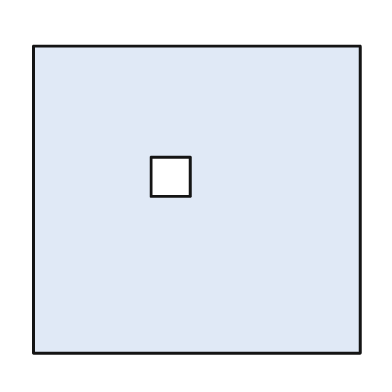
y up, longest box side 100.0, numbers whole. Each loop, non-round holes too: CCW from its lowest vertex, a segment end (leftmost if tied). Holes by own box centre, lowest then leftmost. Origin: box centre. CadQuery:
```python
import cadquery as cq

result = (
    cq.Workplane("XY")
    .moveTo(-50.0, -47.0)
    .lineTo(50.0, -47.0)
    .lineTo(50.0, 47.0)
    .lineTo(-50.0, 47.0)
    .close()
    .moveTo(-14.0, 1.0)
    .lineTo(-2.0, 1.0)
    .lineTo(-2.0, 13.0)
    .lineTo(-14.0, 13.0)
    .close()
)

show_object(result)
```